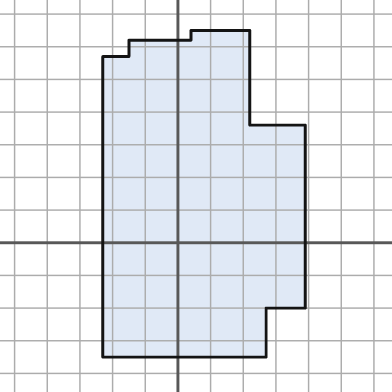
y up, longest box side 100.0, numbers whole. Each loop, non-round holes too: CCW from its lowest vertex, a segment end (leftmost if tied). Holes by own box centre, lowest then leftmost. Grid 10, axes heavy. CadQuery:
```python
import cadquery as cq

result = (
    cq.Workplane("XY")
    .moveTo(-23.0, -35.0)
    .lineTo(27.0, -35.0)
    .lineTo(27.0, -20.0)
    .lineTo(39.0, -20.0)
    .lineTo(39.0, 36.0)
    .lineTo(22.0, 36.0)
    .lineTo(22.0, 65.0)
    .lineTo(4.0, 65.0)
    .lineTo(4.0, 62.0)
    .lineTo(-15.0, 62.0)
    .lineTo(-15.0, 57.0)
    .lineTo(-23.0, 57.0)
    .close()
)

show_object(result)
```